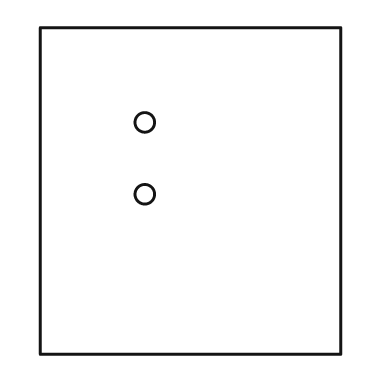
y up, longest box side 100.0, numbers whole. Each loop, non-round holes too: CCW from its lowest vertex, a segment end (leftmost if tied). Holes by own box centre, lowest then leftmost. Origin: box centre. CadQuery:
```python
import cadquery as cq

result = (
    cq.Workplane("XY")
    .moveTo(-46.0, -50.0)
    .lineTo(46.0, -50.0)
    .lineTo(46.0, 50.0)
    .lineTo(-46.0, 50.0)
    .close()
    .moveTo(-14.0, -1.0)
    .circle(3.0)
    .moveTo(-14.0, 21.0)
    .circle(3.0)
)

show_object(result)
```